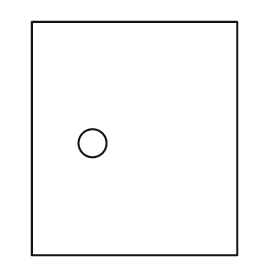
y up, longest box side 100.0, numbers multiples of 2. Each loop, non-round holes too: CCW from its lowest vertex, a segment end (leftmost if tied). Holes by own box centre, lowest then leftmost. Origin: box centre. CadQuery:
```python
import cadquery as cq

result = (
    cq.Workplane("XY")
    .moveTo(-44.0, -50.0)
    .lineTo(44.0, -50.0)
    .lineTo(44.0, 50.0)
    .lineTo(-44.0, 50.0)
    .close()
    .moveTo(-18.0, -2.0)
    .circle(6.0)
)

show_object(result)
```